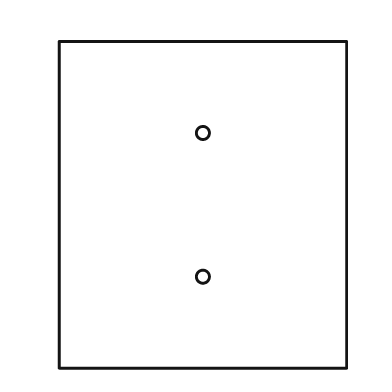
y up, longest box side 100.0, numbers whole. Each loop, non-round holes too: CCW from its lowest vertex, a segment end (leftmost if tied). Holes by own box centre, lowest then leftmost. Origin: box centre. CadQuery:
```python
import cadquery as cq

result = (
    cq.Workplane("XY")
    .moveTo(-44.0, -50.0)
    .lineTo(44.0, -50.0)
    .lineTo(44.0, 50.0)
    .lineTo(-44.0, 50.0)
    .close()
    .moveTo(0.0, -22.0)
    .circle(2.0)
    .moveTo(0.0, 22.0)
    .circle(2.0)
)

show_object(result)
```